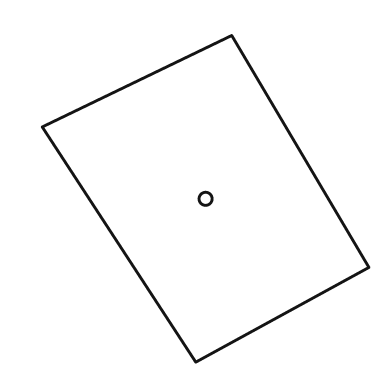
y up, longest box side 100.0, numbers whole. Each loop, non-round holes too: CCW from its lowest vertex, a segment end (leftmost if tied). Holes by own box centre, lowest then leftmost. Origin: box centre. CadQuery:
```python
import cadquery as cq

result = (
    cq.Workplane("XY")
    .moveTo(-3.0, -50.0)
    .lineTo(50.0, -21.0)
    .lineTo(8.0, 50.0)
    .lineTo(-50.0, 22.0)
    .close()
    .moveTo(0.0, 0.0)
    .circle(2.0)
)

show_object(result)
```